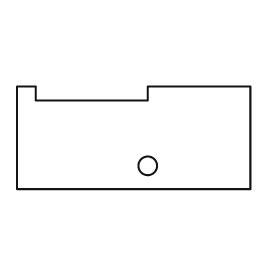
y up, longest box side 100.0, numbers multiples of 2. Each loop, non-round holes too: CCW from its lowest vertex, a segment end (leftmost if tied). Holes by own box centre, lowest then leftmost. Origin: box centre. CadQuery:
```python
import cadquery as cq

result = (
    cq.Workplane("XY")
    .moveTo(-50.0, -22.0)
    .lineTo(50.0, -22.0)
    .lineTo(50.0, 22.0)
    .lineTo(6.0, 22.0)
    .lineTo(6.0, 16.0)
    .lineTo(-42.0, 16.0)
    .lineTo(-42.0, 22.0)
    .lineTo(-50.0, 22.0)
    .close()
    .moveTo(6.0, -12.0)
    .circle(4.0)
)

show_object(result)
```